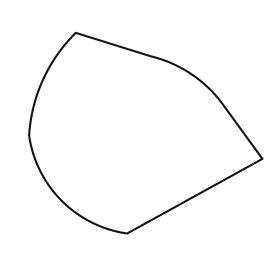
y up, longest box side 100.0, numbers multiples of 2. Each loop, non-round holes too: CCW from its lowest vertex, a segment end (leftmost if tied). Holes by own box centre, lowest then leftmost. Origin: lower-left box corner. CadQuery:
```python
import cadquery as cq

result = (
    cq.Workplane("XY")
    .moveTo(42.0, 0.0)
    .lineTo(100.0, 32.0)
    .lineTo(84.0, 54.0)
    .threePointArc((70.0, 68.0), (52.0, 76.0))
    .lineTo(20.0, 86.0)
    .threePointArc((6.0, 66.0), (0.0, 42.0))
    .threePointArc((14.0, 14.0), (42.0, 0.0))
    .close()
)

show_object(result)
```